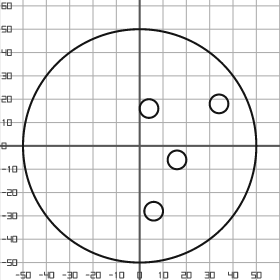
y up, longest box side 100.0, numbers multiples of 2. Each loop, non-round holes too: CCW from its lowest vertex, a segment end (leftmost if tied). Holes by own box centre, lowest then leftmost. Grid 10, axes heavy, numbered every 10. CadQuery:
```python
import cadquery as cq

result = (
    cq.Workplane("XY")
    .moveTo(0.0, 0.0)
    .circle(50.0)
    .moveTo(6.0, -28.0)
    .circle(4.0)
    .moveTo(16.0, -6.0)
    .circle(4.0)
    .moveTo(4.0, 16.0)
    .circle(4.0)
    .moveTo(34.0, 18.0)
    .circle(4.0)
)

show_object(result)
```